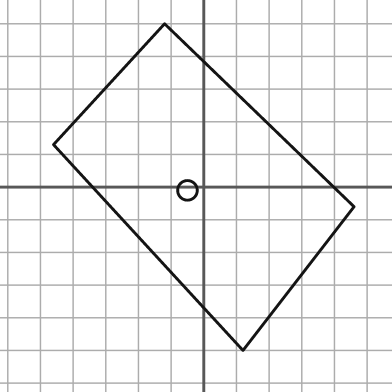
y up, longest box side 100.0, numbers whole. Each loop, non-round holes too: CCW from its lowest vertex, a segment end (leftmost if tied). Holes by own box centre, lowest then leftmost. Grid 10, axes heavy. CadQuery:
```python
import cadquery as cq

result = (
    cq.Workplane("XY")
    .moveTo(12.0, -50.0)
    .lineTo(46.0, -6.0)
    .lineTo(-12.0, 50.0)
    .lineTo(-46.0, 13.0)
    .close()
    .moveTo(-5.0, -1.0)
    .circle(3.0)
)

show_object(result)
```